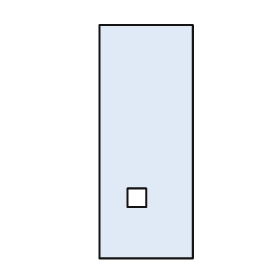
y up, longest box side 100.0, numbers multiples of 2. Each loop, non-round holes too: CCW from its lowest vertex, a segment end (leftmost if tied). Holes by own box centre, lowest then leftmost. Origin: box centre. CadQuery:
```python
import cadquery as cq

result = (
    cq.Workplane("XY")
    .moveTo(-20.0, -50.0)
    .lineTo(20.0, -50.0)
    .lineTo(20.0, 50.0)
    .lineTo(-20.0, 50.0)
    .close()
    .moveTo(-8.0, -28.0)
    .lineTo(0.0, -28.0)
    .lineTo(0.0, -20.0)
    .lineTo(-8.0, -20.0)
    .close()
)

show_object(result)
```